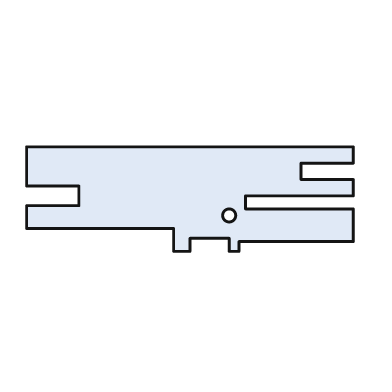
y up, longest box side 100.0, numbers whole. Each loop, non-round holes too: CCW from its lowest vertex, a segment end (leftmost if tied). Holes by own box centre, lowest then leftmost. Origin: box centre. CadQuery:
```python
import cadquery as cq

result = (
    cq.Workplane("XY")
    .moveTo(-5.0, -16.0)
    .lineTo(0.0, -16.0)
    .lineTo(0.0, -12.0)
    .lineTo(12.0, -12.0)
    .lineTo(12.0, -16.0)
    .lineTo(15.0, -16.0)
    .lineTo(15.0, -13.0)
    .lineTo(50.0, -13.0)
    .lineTo(50.0, -3.0)
    .lineTo(17.0, -3.0)
    .lineTo(17.0, 1.0)
    .lineTo(50.0, 1.0)
    .lineTo(50.0, 6.0)
    .lineTo(34.0, 6.0)
    .lineTo(34.0, 11.0)
    .lineTo(50.0, 11.0)
    .lineTo(50.0, 16.0)
    .lineTo(-50.0, 16.0)
    .lineTo(-50.0, 4.0)
    .lineTo(-34.0, 4.0)
    .lineTo(-34.0, -2.0)
    .lineTo(-50.0, -2.0)
    .lineTo(-50.0, -9.0)
    .lineTo(-5.0, -9.0)
    .close()
    .moveTo(12.0, -5.0)
    .circle(2.0)
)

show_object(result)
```